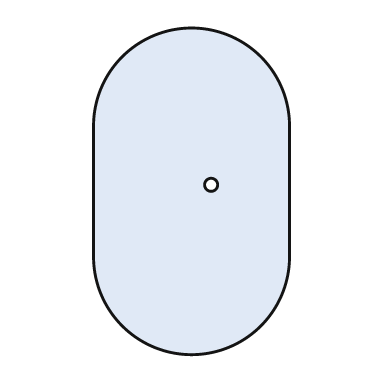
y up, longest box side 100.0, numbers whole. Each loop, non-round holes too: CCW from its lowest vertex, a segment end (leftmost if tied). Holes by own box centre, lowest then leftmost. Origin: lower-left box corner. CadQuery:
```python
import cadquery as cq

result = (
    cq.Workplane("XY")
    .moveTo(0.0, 30.0)
    .threePointArc((30.0, 0.0), (60.0, 30.0))
    .lineTo(60.0, 70.0)
    .threePointArc((30.0, 100.0), (0.0, 70.0))
    .close()
    .moveTo(36.0, 52.0)
    .circle(2.0)
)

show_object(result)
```